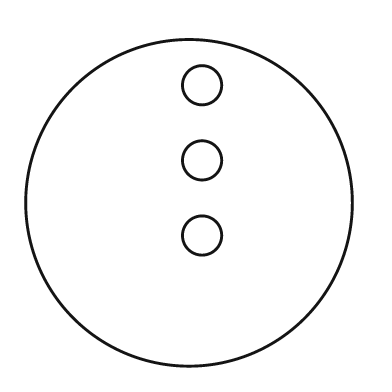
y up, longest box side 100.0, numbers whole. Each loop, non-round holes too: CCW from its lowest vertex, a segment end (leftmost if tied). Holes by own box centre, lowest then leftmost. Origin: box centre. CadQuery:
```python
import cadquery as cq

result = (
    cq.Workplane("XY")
    .moveTo(0.0, 0.0)
    .circle(50.0)
    .moveTo(4.0, -10.0)
    .circle(6.0)
    .moveTo(4.0, 13.0)
    .circle(6.0)
    .moveTo(4.0, 36.0)
    .circle(6.0)
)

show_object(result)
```